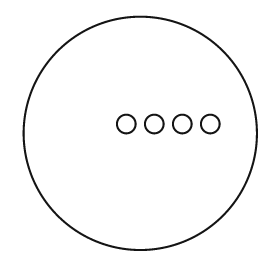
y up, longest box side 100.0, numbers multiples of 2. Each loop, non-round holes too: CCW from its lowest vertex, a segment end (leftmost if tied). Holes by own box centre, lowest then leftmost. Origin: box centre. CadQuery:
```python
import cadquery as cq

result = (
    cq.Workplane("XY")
    .moveTo(0.0, 0.0)
    .circle(50.0)
    .moveTo(-6.0, 4.0)
    .circle(4.0)
    .moveTo(6.0, 4.0)
    .circle(4.0)
    .moveTo(18.0, 4.0)
    .circle(4.0)
    .moveTo(30.0, 4.0)
    .circle(4.0)
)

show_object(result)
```